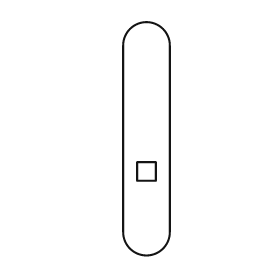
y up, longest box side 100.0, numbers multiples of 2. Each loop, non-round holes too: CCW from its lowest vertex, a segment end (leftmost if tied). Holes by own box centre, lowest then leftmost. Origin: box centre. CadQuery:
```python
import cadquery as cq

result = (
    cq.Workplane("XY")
    .moveTo(-10.0, -40.0)
    .threePointArc((0.0, -50.0), (10.0, -40.0))
    .lineTo(10.0, 40.0)
    .threePointArc((0.0, 50.0), (-10.0, 40.0))
    .close()
    .moveTo(-4.0, -18.0)
    .lineTo(4.0, -18.0)
    .lineTo(4.0, -10.0)
    .lineTo(-4.0, -10.0)
    .close()
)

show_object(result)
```